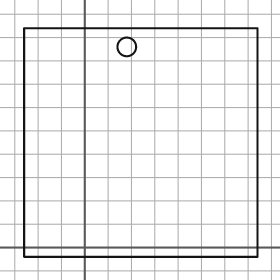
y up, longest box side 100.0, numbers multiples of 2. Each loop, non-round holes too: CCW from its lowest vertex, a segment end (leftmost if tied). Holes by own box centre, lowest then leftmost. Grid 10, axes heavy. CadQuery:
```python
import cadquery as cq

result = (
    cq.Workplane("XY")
    .moveTo(-26.0, -4.0)
    .lineTo(74.0, -4.0)
    .lineTo(74.0, 94.0)
    .lineTo(-26.0, 94.0)
    .close()
    .moveTo(18.0, 86.0)
    .circle(4.0)
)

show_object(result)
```